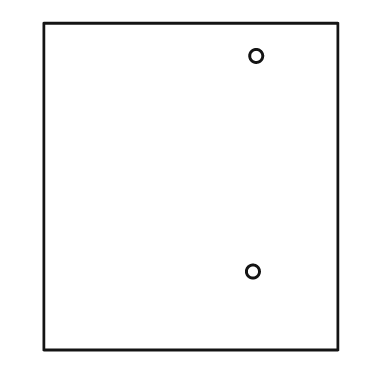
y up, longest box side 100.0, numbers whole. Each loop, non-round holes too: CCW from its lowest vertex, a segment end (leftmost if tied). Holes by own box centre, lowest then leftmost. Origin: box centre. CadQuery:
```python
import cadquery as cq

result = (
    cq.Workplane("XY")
    .moveTo(-45.0, -50.0)
    .lineTo(45.0, -50.0)
    .lineTo(45.0, 50.0)
    .lineTo(-45.0, 50.0)
    .close()
    .moveTo(19.0, -26.0)
    .circle(2.0)
    .moveTo(20.0, 40.0)
    .circle(2.0)
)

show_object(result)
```